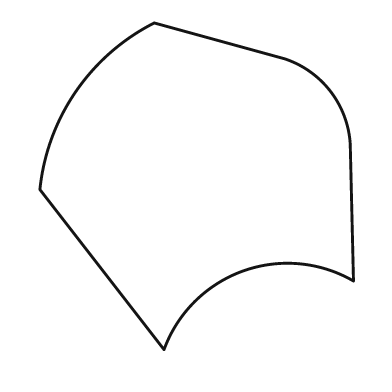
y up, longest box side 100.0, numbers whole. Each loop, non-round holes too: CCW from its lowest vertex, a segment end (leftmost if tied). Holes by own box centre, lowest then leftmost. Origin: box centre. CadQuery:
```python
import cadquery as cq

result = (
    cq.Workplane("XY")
    .moveTo(-10.0, -50.0)
    .threePointArc((14.0, -26.0), (48.0, -29.0))
    .lineTo(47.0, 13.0)
    .threePointArc((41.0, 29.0), (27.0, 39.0))
    .lineTo(-13.0, 50.0)
    .threePointArc((-37.0, 29.0), (-48.0, -1.0))
    .close()
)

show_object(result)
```